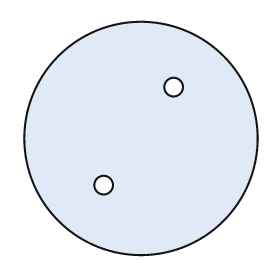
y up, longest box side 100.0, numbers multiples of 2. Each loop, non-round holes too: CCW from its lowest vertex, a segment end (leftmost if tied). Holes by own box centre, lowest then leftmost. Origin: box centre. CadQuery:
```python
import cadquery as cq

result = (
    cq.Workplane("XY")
    .moveTo(0.0, 0.0)
    .circle(50.0)
    .moveTo(-16.0, -20.0)
    .circle(4.0)
    .moveTo(14.0, 22.0)
    .circle(4.0)
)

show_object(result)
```